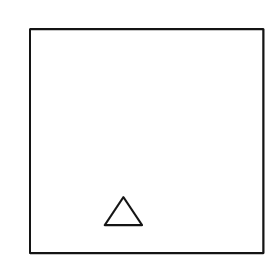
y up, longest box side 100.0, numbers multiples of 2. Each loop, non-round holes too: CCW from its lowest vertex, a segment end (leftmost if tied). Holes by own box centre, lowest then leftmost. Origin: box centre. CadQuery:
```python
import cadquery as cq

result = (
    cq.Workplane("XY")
    .moveTo(-50.0, -48.0)
    .lineTo(50.0, -48.0)
    .lineTo(50.0, 48.0)
    .lineTo(-50.0, 48.0)
    .close()
    .moveTo(-18.0, -36.0)
    .lineTo(-2.0, -36.0)
    .lineTo(-10.0, -24.0)
    .close()
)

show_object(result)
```